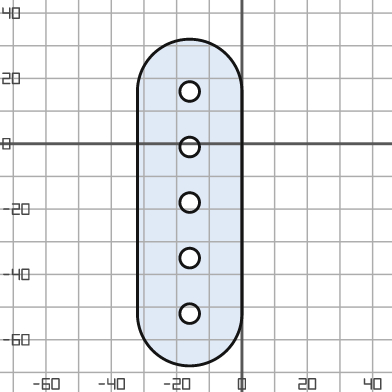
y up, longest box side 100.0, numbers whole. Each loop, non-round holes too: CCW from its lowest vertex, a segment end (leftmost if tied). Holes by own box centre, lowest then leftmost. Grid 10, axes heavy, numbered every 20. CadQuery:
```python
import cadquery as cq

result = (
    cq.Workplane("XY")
    .moveTo(-32.0, -52.0)
    .threePointArc((-16.0, -68.0), (0.0, -52.0))
    .lineTo(0.0, 16.0)
    .threePointArc((-16.0, 32.0), (-32.0, 16.0))
    .close()
    .moveTo(-16.0, -52.0)
    .circle(3.0)
    .moveTo(-16.0, -35.0)
    .circle(3.0)
    .moveTo(-16.0, -18.0)
    .circle(3.0)
    .moveTo(-16.0, -1.0)
    .circle(3.0)
    .moveTo(-16.0, 16.0)
    .circle(3.0)
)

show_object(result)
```